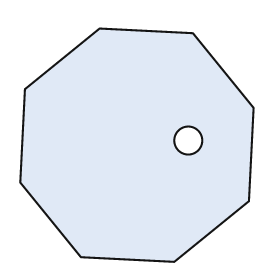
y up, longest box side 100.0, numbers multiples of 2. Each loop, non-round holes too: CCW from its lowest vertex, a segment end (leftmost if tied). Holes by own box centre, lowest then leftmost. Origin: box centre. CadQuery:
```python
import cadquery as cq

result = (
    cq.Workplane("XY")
    .moveTo(16.0, -50.0)
    .lineTo(48.0, -24.0)
    .lineTo(50.0, 16.0)
    .lineTo(24.0, 48.0)
    .lineTo(-16.0, 50.0)
    .lineTo(-48.0, 24.0)
    .lineTo(-50.0, -16.0)
    .lineTo(-24.0, -48.0)
    .close()
    .moveTo(22.0, 2.0)
    .circle(6.0)
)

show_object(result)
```